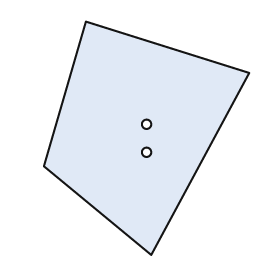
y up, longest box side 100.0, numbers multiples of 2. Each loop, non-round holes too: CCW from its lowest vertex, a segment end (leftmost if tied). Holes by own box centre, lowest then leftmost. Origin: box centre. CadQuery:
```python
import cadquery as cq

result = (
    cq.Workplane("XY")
    .moveTo(2.0, -50.0)
    .lineTo(44.0, 28.0)
    .lineTo(-26.0, 50.0)
    .lineTo(-44.0, -12.0)
    .close()
    .moveTo(0.0, -6.0)
    .circle(2.0)
    .moveTo(0.0, 6.0)
    .circle(2.0)
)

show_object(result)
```